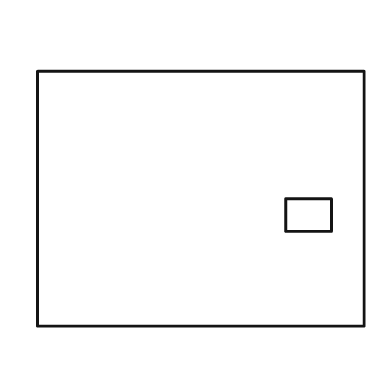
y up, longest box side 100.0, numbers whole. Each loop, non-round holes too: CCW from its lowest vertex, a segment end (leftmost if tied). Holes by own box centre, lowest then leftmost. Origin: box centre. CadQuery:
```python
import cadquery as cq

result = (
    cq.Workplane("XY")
    .moveTo(-50.0, -39.0)
    .lineTo(50.0, -39.0)
    .lineTo(50.0, 39.0)
    .lineTo(-50.0, 39.0)
    .close()
    .moveTo(26.0, -10.0)
    .lineTo(40.0, -10.0)
    .lineTo(40.0, 0.0)
    .lineTo(26.0, 0.0)
    .close()
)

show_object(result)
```